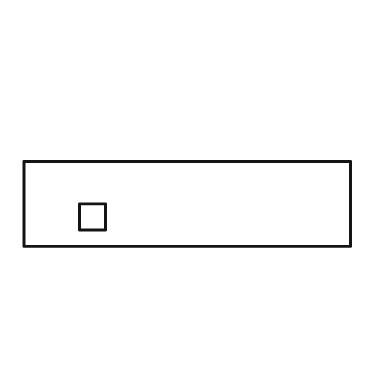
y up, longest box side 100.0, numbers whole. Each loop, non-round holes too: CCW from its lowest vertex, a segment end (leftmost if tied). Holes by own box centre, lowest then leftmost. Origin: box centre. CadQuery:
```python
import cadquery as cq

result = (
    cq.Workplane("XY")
    .moveTo(-50.0, -13.0)
    .lineTo(50.0, -13.0)
    .lineTo(50.0, 13.0)
    .lineTo(-50.0, 13.0)
    .close()
    .moveTo(-33.0, -8.0)
    .lineTo(-25.0, -8.0)
    .lineTo(-25.0, 0.0)
    .lineTo(-33.0, 0.0)
    .close()
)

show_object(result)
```